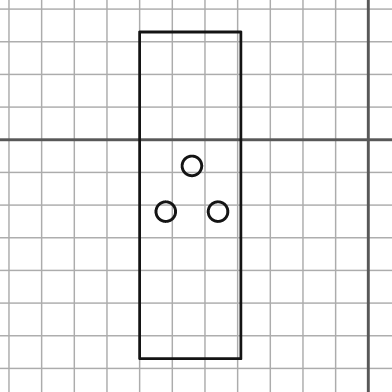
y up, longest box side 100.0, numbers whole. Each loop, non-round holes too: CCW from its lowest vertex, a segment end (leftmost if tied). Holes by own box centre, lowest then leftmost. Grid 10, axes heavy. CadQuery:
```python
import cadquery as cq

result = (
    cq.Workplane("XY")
    .moveTo(-70.0, -67.0)
    .lineTo(-39.0, -67.0)
    .lineTo(-39.0, 33.0)
    .lineTo(-70.0, 33.0)
    .close()
    .moveTo(-62.0, -22.0)
    .circle(3.0)
    .moveTo(-46.0, -22.0)
    .circle(3.0)
    .moveTo(-54.0, -8.0)
    .circle(3.0)
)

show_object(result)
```